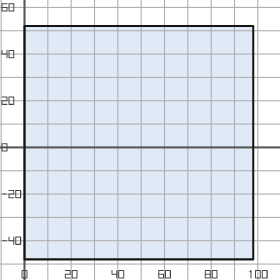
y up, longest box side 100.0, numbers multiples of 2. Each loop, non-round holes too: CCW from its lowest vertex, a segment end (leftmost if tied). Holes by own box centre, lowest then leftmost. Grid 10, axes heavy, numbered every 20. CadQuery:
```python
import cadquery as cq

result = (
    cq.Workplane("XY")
    .moveTo(0.0, -48.0)
    .lineTo(98.0, -48.0)
    .lineTo(98.0, 52.0)
    .lineTo(0.0, 52.0)
    .close()
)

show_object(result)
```